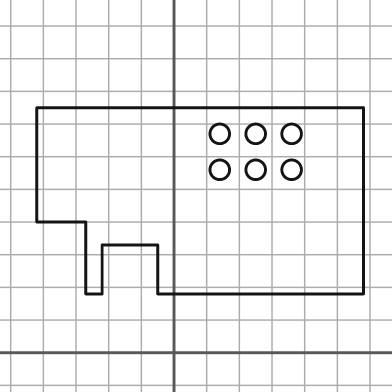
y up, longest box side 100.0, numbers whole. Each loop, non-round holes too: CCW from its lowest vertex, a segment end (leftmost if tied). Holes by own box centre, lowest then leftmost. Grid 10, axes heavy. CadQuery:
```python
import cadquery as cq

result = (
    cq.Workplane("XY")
    .moveTo(-27.0, 18.0)
    .lineTo(-22.0, 18.0)
    .lineTo(-22.0, 33.0)
    .lineTo(-5.0, 33.0)
    .lineTo(-5.0, 18.0)
    .lineTo(58.0, 18.0)
    .lineTo(58.0, 75.0)
    .lineTo(-42.0, 75.0)
    .lineTo(-42.0, 40.0)
    .lineTo(-27.0, 40.0)
    .close()
    .moveTo(14.0, 56.0)
    .circle(3.0)
    .moveTo(25.0, 56.0)
    .circle(3.0)
    .moveTo(36.0, 56.0)
    .circle(3.0)
    .moveTo(14.0, 67.0)
    .circle(3.0)
    .moveTo(25.0, 67.0)
    .circle(3.0)
    .moveTo(36.0, 67.0)
    .circle(3.0)
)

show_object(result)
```